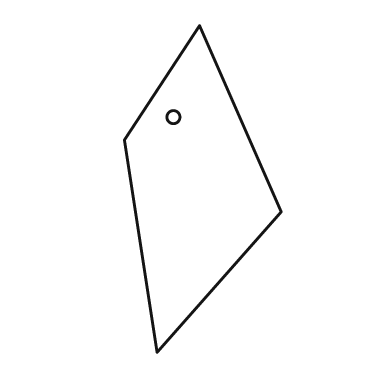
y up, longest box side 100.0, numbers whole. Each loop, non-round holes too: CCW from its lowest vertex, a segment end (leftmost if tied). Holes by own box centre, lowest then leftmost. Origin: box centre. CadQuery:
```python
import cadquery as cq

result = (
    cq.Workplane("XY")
    .moveTo(-14.0, -50.0)
    .lineTo(24.0, -7.0)
    .lineTo(-1.0, 50.0)
    .lineTo(-24.0, 15.0)
    .close()
    .moveTo(-9.0, 22.0)
    .circle(2.0)
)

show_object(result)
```